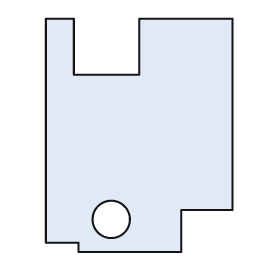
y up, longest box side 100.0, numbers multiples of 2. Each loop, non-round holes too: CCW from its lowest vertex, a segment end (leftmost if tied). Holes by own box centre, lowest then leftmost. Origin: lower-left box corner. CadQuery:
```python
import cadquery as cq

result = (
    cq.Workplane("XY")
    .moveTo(14.0, 0.0)
    .lineTo(58.0, 0.0)
    .lineTo(58.0, 18.0)
    .lineTo(80.0, 18.0)
    .lineTo(80.0, 100.0)
    .lineTo(40.0, 100.0)
    .lineTo(40.0, 76.0)
    .lineTo(12.0, 76.0)
    .lineTo(12.0, 100.0)
    .lineTo(0.0, 100.0)
    .lineTo(0.0, 4.0)
    .lineTo(14.0, 4.0)
    .close()
    .moveTo(28.0, 14.0)
    .circle(8.0)
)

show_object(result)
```